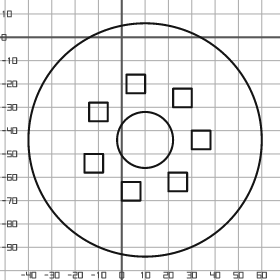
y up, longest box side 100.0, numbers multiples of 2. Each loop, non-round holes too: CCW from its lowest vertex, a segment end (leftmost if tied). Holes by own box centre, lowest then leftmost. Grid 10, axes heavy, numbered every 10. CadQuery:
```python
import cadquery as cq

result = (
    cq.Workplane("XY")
    .moveTo(10.0, -44.0)
    .circle(50.0)
    .moveTo(0.0, -70.0)
    .lineTo(8.0, -70.0)
    .lineTo(8.0, -62.0)
    .lineTo(0.0, -62.0)
    .close()
    .moveTo(20.0, -66.0)
    .lineTo(28.0, -66.0)
    .lineTo(28.0, -58.0)
    .lineTo(20.0, -58.0)
    .close()
    .moveTo(-16.0, -58.0)
    .lineTo(-8.0, -58.0)
    .lineTo(-8.0, -50.0)
    .lineTo(-16.0, -50.0)
    .close()
    .moveTo(10.0, -44.0)
    .circle(12.0)
    .moveTo(30.0, -48.0)
    .lineTo(38.0, -48.0)
    .lineTo(38.0, -40.0)
    .lineTo(30.0, -40.0)
    .close()
    .moveTo(-14.0, -36.0)
    .lineTo(-6.0, -36.0)
    .lineTo(-6.0, -28.0)
    .lineTo(-14.0, -28.0)
    .close()
    .moveTo(22.0, -30.0)
    .lineTo(30.0, -30.0)
    .lineTo(30.0, -22.0)
    .lineTo(22.0, -22.0)
    .close()
    .moveTo(2.0, -24.0)
    .lineTo(10.0, -24.0)
    .lineTo(10.0, -16.0)
    .lineTo(2.0, -16.0)
    .close()
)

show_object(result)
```